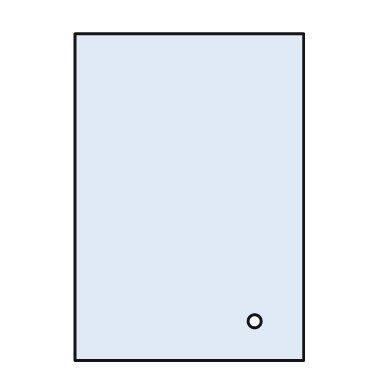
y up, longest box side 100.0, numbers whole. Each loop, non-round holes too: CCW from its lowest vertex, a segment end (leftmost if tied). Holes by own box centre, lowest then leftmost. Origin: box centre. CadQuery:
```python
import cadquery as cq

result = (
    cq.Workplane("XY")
    .moveTo(-35.0, -50.0)
    .lineTo(35.0, -50.0)
    .lineTo(35.0, 50.0)
    .lineTo(-35.0, 50.0)
    .close()
    .moveTo(20.0, -38.0)
    .circle(2.0)
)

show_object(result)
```